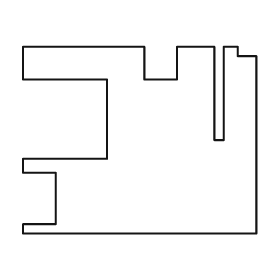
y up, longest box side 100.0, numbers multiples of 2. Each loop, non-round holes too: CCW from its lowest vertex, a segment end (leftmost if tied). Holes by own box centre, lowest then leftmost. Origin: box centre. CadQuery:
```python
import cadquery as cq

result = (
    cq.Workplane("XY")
    .moveTo(-50.0, -40.0)
    .lineTo(50.0, -40.0)
    .lineTo(50.0, 36.0)
    .lineTo(42.0, 36.0)
    .lineTo(42.0, 40.0)
    .lineTo(36.0, 40.0)
    .lineTo(36.0, 0.0)
    .lineTo(32.0, 0.0)
    .lineTo(32.0, 40.0)
    .lineTo(16.0, 40.0)
    .lineTo(16.0, 26.0)
    .lineTo(2.0, 26.0)
    .lineTo(2.0, 40.0)
    .lineTo(-50.0, 40.0)
    .lineTo(-50.0, 26.0)
    .lineTo(-14.0, 26.0)
    .lineTo(-14.0, -8.0)
    .lineTo(-50.0, -8.0)
    .lineTo(-50.0, -14.0)
    .lineTo(-36.0, -14.0)
    .lineTo(-36.0, -36.0)
    .lineTo(-50.0, -36.0)
    .close()
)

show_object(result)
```